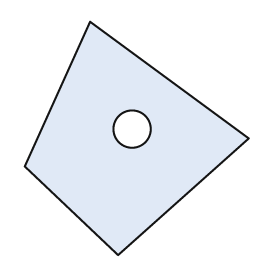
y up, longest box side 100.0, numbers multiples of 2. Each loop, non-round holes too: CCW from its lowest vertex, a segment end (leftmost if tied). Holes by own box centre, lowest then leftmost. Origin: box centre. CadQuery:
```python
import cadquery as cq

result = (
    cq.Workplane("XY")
    .moveTo(-8.0, -50.0)
    .lineTo(48.0, 0.0)
    .lineTo(-20.0, 50.0)
    .lineTo(-48.0, -12.0)
    .close()
    .moveTo(-2.0, 4.0)
    .circle(8.0)
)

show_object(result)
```